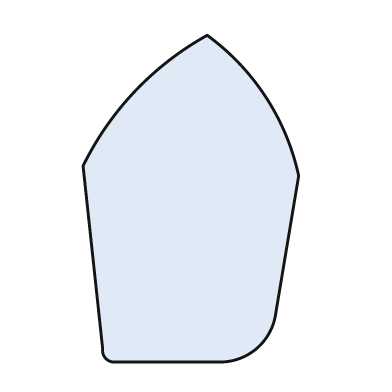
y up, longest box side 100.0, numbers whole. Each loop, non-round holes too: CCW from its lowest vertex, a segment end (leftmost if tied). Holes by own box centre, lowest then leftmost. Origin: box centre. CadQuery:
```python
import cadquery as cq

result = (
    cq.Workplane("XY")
    .moveTo(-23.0, -50.0)
    .lineTo(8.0, -50.0)
    .threePointArc((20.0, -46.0), (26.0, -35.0))
    .lineTo(33.0, 7.0)
    .threePointArc((23.0, 31.0), (5.0, 50.0))
    .threePointArc((-17.0, 33.0), (-33.0, 10.0))
    .lineTo(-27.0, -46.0)
    .threePointArc((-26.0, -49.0), (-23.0, -50.0))
    .close()
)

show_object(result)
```